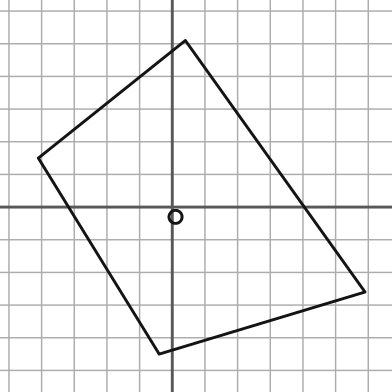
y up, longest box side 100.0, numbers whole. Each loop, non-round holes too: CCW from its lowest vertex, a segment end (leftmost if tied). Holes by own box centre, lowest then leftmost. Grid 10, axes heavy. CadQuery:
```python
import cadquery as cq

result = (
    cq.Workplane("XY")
    .moveTo(-4.0, -45.0)
    .lineTo(59.0, -26.0)
    .lineTo(4.0, 51.0)
    .lineTo(-41.0, 15.0)
    .close()
    .moveTo(1.0, -3.0)
    .circle(2.0)
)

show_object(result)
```